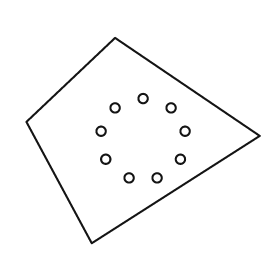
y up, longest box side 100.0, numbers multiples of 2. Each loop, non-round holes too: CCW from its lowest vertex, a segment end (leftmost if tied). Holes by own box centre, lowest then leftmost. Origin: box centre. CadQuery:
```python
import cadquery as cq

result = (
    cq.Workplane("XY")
    .moveTo(-22.0, -44.0)
    .lineTo(50.0, 2.0)
    .lineTo(-12.0, 44.0)
    .lineTo(-50.0, 8.0)
    .close()
    .moveTo(-6.0, -16.0)
    .circle(2.0)
    .moveTo(6.0, -16.0)
    .circle(2.0)
    .moveTo(-16.0, -8.0)
    .circle(2.0)
    .moveTo(16.0, -8.0)
    .circle(2.0)
    .moveTo(-18.0, 4.0)
    .circle(2.0)
    .moveTo(18.0, 4.0)
    .circle(2.0)
    .moveTo(-12.0, 14.0)
    .circle(2.0)
    .moveTo(12.0, 14.0)
    .circle(2.0)
    .moveTo(0.0, 18.0)
    .circle(2.0)
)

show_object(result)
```